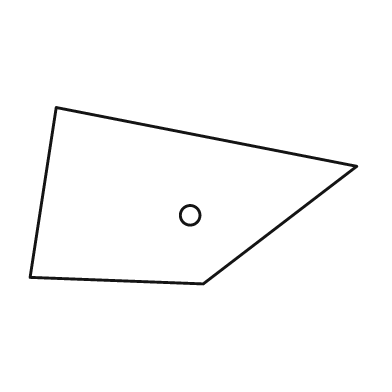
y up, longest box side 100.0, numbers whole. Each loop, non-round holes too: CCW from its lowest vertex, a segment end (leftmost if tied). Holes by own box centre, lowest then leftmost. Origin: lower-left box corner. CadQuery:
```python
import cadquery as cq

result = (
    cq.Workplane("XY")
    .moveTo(53.0, 0.0)
    .lineTo(100.0, 36.0)
    .lineTo(8.0, 54.0)
    .lineTo(0.0, 2.0)
    .close()
    .moveTo(49.0, 21.0)
    .circle(3.0)
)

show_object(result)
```